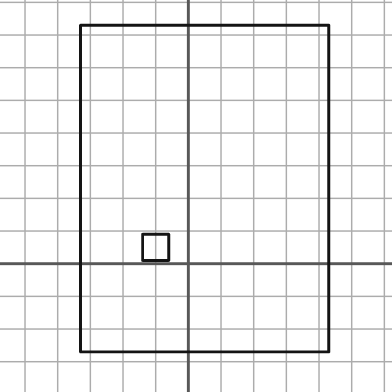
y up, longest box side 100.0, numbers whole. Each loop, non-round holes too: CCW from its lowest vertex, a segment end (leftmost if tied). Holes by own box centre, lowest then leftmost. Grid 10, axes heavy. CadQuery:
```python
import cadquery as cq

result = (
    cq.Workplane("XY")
    .moveTo(-33.0, -27.0)
    .lineTo(43.0, -27.0)
    .lineTo(43.0, 73.0)
    .lineTo(-33.0, 73.0)
    .close()
    .moveTo(-14.0, 1.0)
    .lineTo(-6.0, 1.0)
    .lineTo(-6.0, 9.0)
    .lineTo(-14.0, 9.0)
    .close()
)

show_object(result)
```